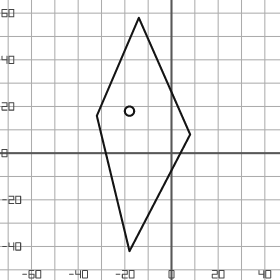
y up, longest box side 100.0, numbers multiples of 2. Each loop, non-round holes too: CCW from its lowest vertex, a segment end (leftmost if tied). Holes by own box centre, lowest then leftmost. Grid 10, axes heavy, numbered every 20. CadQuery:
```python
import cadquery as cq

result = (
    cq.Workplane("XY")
    .moveTo(-18.0, -42.0)
    .lineTo(8.0, 8.0)
    .lineTo(-14.0, 58.0)
    .lineTo(-32.0, 16.0)
    .close()
    .moveTo(-18.0, 18.0)
    .circle(2.0)
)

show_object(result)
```